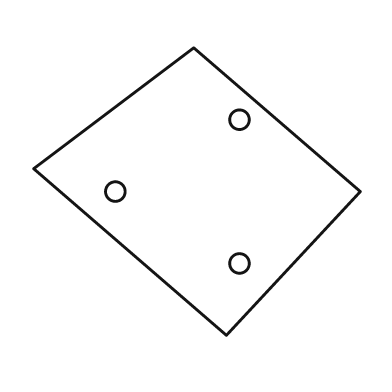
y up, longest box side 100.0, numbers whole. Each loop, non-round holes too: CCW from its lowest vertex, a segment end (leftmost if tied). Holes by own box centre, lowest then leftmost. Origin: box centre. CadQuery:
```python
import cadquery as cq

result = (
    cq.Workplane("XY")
    .moveTo(9.0, -44.0)
    .lineTo(50.0, 0.0)
    .lineTo(-1.0, 44.0)
    .lineTo(-50.0, 7.0)
    .close()
    .moveTo(13.0, -22.0)
    .circle(3.0)
    .moveTo(-25.0, 0.0)
    .circle(3.0)
    .moveTo(13.0, 22.0)
    .circle(3.0)
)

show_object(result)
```